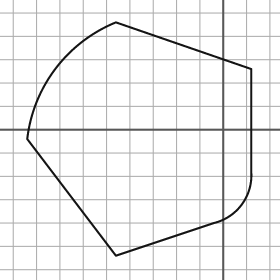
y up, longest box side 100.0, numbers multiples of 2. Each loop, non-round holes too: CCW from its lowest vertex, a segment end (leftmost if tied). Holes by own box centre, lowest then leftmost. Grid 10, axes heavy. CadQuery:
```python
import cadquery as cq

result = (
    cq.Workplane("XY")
    .moveTo(-46.0, -54.0)
    .lineTo(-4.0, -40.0)
    .threePointArc((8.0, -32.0), (12.0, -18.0))
    .lineTo(12.0, 26.0)
    .lineTo(-46.0, 46.0)
    .threePointArc((-72.0, 26.0), (-84.0, -4.0))
    .close()
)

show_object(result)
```